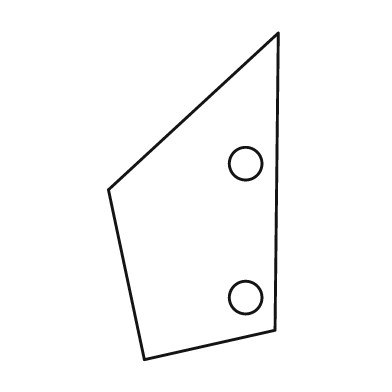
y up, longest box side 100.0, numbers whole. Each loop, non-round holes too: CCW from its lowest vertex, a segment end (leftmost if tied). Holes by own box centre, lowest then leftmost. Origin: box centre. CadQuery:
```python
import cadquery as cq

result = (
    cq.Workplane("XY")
    .moveTo(-15.0, -50.0)
    .lineTo(25.0, -41.0)
    .lineTo(26.0, 50.0)
    .lineTo(-26.0, 2.0)
    .close()
    .moveTo(16.0, -31.0)
    .circle(5.0)
    .moveTo(16.0, 10.0)
    .circle(5.0)
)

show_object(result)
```